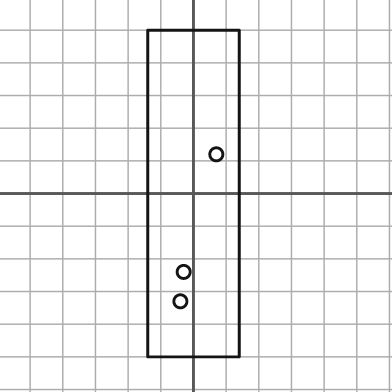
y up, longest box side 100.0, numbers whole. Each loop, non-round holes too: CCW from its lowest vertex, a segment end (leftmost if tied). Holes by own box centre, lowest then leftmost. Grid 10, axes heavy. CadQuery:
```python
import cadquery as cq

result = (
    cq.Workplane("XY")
    .moveTo(-14.0, -50.0)
    .lineTo(14.0, -50.0)
    .lineTo(14.0, 50.0)
    .lineTo(-14.0, 50.0)
    .close()
    .moveTo(-4.0, -33.0)
    .circle(2.0)
    .moveTo(-3.0, -24.0)
    .circle(2.0)
    .moveTo(7.0, 12.0)
    .circle(2.0)
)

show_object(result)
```